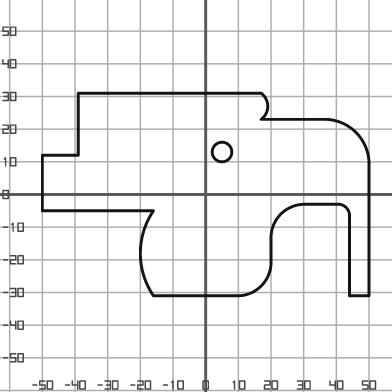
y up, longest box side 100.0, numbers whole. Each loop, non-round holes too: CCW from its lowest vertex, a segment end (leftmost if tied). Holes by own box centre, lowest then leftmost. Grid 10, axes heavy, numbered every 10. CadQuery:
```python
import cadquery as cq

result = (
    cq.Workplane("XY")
    .moveTo(-16.0, -31.0)
    .lineTo(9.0, -31.0)
    .threePointArc((17.0, -28.0), (20.0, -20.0))
    .lineTo(20.0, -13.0)
    .threePointArc((23.0, -6.0), (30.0, -3.0))
    .lineTo(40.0, -3.0)
    .threePointArc((43.0, -4.0), (44.0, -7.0))
    .lineTo(44.0, -31.0)
    .lineTo(50.0, -31.0)
    .lineTo(50.0, 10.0)
    .threePointArc((46.0, 19.0), (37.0, 23.0))
    .lineTo(17.0, 23.0)
    .threePointArc((19.0, 27.0), (17.0, 31.0))
    .lineTo(-39.0, 31.0)
    .lineTo(-39.0, 12.0)
    .lineTo(-50.0, 12.0)
    .lineTo(-50.0, -5.0)
    .lineTo(-16.0, -5.0)
    .threePointArc((-20.0, -18.0), (-16.0, -31.0))
    .close()
    .moveTo(5.0, 13.0)
    .circle(3.0)
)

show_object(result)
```